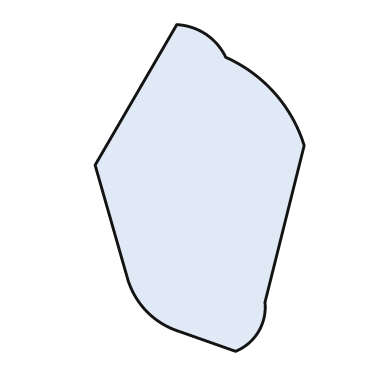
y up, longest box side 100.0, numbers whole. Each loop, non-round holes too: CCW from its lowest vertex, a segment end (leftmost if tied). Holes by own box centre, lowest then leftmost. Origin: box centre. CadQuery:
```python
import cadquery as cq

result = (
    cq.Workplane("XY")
    .moveTo(11.0, -50.0)
    .threePointArc((18.0, -44.0), (20.0, -35.0))
    .lineTo(32.0, 13.0)
    .threePointArc((23.0, 29.0), (8.0, 40.0))
    .threePointArc((2.0, 47.0), (-7.0, 50.0))
    .lineTo(-32.0, 7.0)
    .lineTo(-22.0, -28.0)
    .threePointArc((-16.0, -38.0), (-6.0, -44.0))
    .close()
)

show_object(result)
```